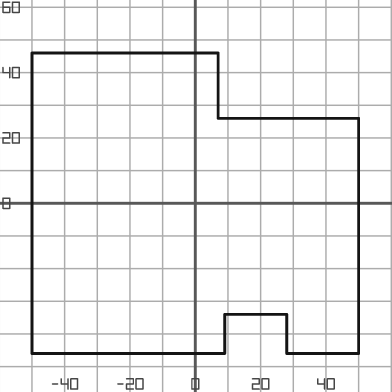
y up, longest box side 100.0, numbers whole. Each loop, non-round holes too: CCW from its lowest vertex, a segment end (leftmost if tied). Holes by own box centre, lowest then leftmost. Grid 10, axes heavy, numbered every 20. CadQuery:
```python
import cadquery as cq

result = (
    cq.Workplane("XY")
    .moveTo(-50.0, -46.0)
    .lineTo(9.0, -46.0)
    .lineTo(9.0, -34.0)
    .lineTo(28.0, -34.0)
    .lineTo(28.0, -46.0)
    .lineTo(50.0, -46.0)
    .lineTo(50.0, 26.0)
    .lineTo(7.0, 26.0)
    .lineTo(7.0, 46.0)
    .lineTo(-50.0, 46.0)
    .close()
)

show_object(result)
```